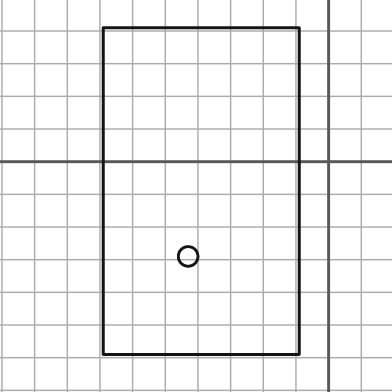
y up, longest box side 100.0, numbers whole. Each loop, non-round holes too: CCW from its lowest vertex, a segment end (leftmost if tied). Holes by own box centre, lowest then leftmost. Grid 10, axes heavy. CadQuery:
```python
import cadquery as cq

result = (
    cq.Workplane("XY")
    .moveTo(-69.0, -59.0)
    .lineTo(-9.0, -59.0)
    .lineTo(-9.0, 41.0)
    .lineTo(-69.0, 41.0)
    .close()
    .moveTo(-43.0, -29.0)
    .circle(3.0)
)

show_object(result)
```